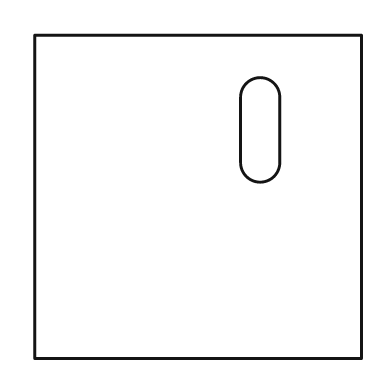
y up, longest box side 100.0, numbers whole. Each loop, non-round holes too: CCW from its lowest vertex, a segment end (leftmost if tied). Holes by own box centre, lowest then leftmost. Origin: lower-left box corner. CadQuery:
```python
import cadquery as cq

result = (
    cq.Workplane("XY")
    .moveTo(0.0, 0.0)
    .lineTo(100.0, 0.0)
    .lineTo(100.0, 99.0)
    .lineTo(0.0, 99.0)
    .close()
    .moveTo(63.0, 60.0)
    .threePointArc((69.0, 54.0), (75.0, 60.0))
    .lineTo(75.0, 80.0)
    .threePointArc((69.0, 86.0), (63.0, 80.0))
    .close()
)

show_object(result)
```